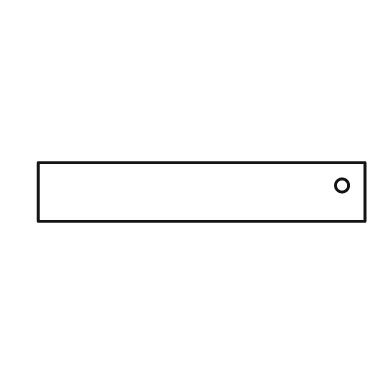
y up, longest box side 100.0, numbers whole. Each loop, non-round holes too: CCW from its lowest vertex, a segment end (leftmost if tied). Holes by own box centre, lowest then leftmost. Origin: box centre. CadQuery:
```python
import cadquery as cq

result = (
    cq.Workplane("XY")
    .moveTo(-50.0, -9.0)
    .lineTo(50.0, -9.0)
    .lineTo(50.0, 9.0)
    .lineTo(-50.0, 9.0)
    .close()
    .moveTo(43.0, 2.0)
    .circle(2.0)
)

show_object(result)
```